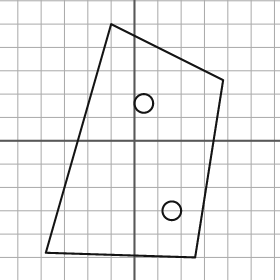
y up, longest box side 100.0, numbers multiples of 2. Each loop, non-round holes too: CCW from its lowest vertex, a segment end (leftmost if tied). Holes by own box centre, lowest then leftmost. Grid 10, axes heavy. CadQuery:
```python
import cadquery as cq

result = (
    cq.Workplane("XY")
    .moveTo(26.0, -50.0)
    .lineTo(38.0, 26.0)
    .lineTo(-10.0, 50.0)
    .lineTo(-38.0, -48.0)
    .close()
    .moveTo(16.0, -30.0)
    .circle(4.0)
    .moveTo(4.0, 16.0)
    .circle(4.0)
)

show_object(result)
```